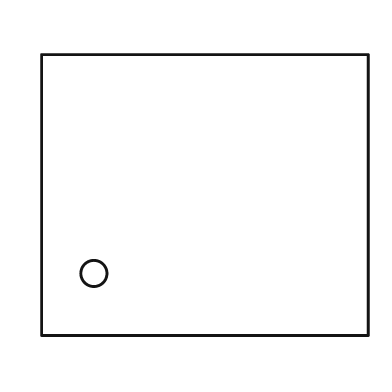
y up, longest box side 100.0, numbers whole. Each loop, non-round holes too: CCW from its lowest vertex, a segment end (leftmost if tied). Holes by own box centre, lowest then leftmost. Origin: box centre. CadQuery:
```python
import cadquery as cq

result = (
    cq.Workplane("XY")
    .moveTo(-50.0, -43.0)
    .lineTo(50.0, -43.0)
    .lineTo(50.0, 43.0)
    .lineTo(-50.0, 43.0)
    .close()
    .moveTo(-34.0, -24.0)
    .circle(4.0)
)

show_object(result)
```